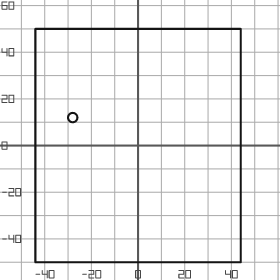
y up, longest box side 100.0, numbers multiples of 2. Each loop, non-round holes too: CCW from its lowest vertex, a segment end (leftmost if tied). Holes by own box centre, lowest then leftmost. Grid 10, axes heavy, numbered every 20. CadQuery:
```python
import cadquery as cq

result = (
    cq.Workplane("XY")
    .moveTo(-44.0, -50.0)
    .lineTo(44.0, -50.0)
    .lineTo(44.0, 50.0)
    .lineTo(-44.0, 50.0)
    .close()
    .moveTo(-28.0, 12.0)
    .circle(2.0)
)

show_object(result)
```